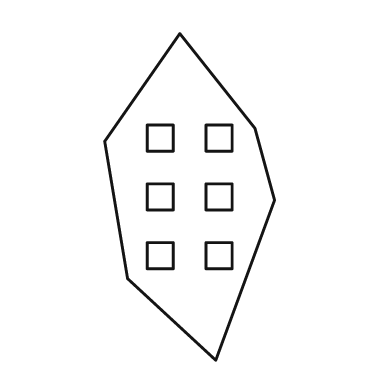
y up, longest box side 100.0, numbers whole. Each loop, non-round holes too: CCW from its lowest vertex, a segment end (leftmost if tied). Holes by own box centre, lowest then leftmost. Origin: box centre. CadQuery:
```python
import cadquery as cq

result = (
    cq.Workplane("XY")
    .moveTo(8.0, -50.0)
    .lineTo(26.0, -1.0)
    .lineTo(20.0, 21.0)
    .lineTo(-3.0, 50.0)
    .lineTo(-26.0, 17.0)
    .lineTo(-19.0, -25.0)
    .close()
    .moveTo(-13.0, -22.0)
    .lineTo(-5.0, -22.0)
    .lineTo(-5.0, -14.0)
    .lineTo(-13.0, -14.0)
    .close()
    .moveTo(5.0, -22.0)
    .lineTo(13.0, -22.0)
    .lineTo(13.0, -14.0)
    .lineTo(5.0, -14.0)
    .close()
    .moveTo(-13.0, -4.0)
    .lineTo(-5.0, -4.0)
    .lineTo(-5.0, 4.0)
    .lineTo(-13.0, 4.0)
    .close()
    .moveTo(5.0, -4.0)
    .lineTo(13.0, -4.0)
    .lineTo(13.0, 4.0)
    .lineTo(5.0, 4.0)
    .close()
    .moveTo(-13.0, 14.0)
    .lineTo(-5.0, 14.0)
    .lineTo(-5.0, 22.0)
    .lineTo(-13.0, 22.0)
    .close()
    .moveTo(5.0, 14.0)
    .lineTo(13.0, 14.0)
    .lineTo(13.0, 22.0)
    .lineTo(5.0, 22.0)
    .close()
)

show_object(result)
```